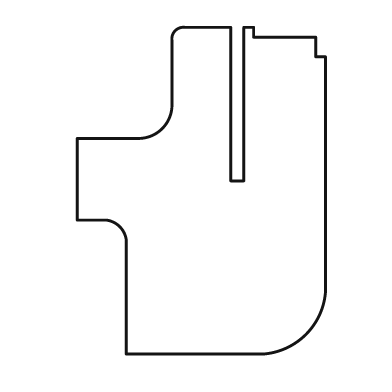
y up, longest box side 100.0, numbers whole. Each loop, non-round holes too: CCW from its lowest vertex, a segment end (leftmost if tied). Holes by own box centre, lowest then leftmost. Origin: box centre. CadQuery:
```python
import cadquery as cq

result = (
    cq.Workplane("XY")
    .moveTo(-23.0, -50.0)
    .lineTo(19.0, -50.0)
    .threePointArc((32.0, -44.0), (38.0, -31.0))
    .lineTo(38.0, 41.0)
    .lineTo(35.0, 41.0)
    .lineTo(35.0, 47.0)
    .lineTo(16.0, 47.0)
    .lineTo(16.0, 50.0)
    .lineTo(13.0, 50.0)
    .lineTo(13.0, 3.0)
    .lineTo(9.0, 3.0)
    .lineTo(9.0, 50.0)
    .lineTo(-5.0, 50.0)
    .threePointArc((-8.0, 49.0), (-9.0, 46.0))
    .lineTo(-9.0, 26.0)
    .threePointArc((-12.0, 19.0), (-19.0, 16.0))
    .lineTo(-38.0, 16.0)
    .lineTo(-38.0, -9.0)
    .lineTo(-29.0, -9.0)
    .threePointArc((-25.0, -11.0), (-23.0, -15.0))
    .close()
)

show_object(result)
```